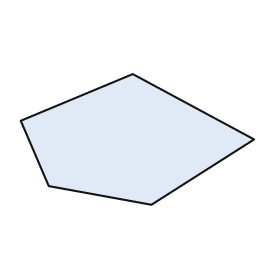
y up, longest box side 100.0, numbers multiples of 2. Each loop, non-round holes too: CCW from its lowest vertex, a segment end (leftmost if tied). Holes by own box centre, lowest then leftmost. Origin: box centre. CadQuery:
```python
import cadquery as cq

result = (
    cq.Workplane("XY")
    .moveTo(6.0, -28.0)
    .lineTo(50.0, 0.0)
    .lineTo(-2.0, 28.0)
    .lineTo(-50.0, 8.0)
    .lineTo(-38.0, -20.0)
    .close()
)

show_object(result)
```